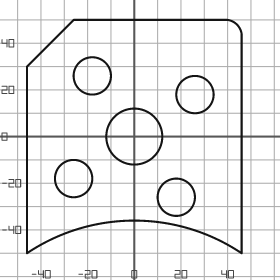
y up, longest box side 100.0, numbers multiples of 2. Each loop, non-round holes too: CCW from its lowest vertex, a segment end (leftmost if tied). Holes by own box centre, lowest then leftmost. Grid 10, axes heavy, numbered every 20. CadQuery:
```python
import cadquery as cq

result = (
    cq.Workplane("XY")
    .moveTo(-46.0, -50.0)
    .threePointArc((0.0, -36.0), (46.0, -50.0))
    .lineTo(46.0, 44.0)
    .threePointArc((44.0, 48.0), (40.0, 50.0))
    .lineTo(-26.0, 50.0)
    .lineTo(-46.0, 30.0)
    .close()
    .moveTo(18.0, -26.0)
    .circle(8.0)
    .moveTo(-26.0, -18.0)
    .circle(8.0)
    .moveTo(0.0, 0.0)
    .circle(12.0)
    .moveTo(26.0, 18.0)
    .circle(8.0)
    .moveTo(-18.0, 26.0)
    .circle(8.0)
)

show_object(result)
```